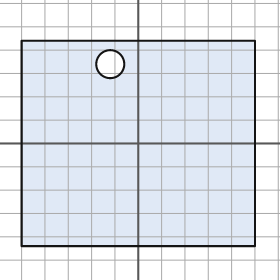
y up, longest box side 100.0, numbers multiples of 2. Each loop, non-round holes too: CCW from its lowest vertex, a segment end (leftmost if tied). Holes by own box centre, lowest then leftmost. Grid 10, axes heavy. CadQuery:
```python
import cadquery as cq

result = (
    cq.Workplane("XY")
    .moveTo(-50.0, -44.0)
    .lineTo(50.0, -44.0)
    .lineTo(50.0, 44.0)
    .lineTo(-50.0, 44.0)
    .close()
    .moveTo(-12.0, 34.0)
    .circle(6.0)
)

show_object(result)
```